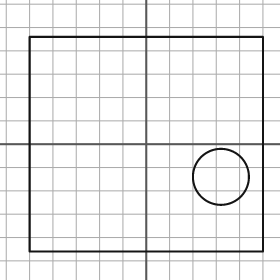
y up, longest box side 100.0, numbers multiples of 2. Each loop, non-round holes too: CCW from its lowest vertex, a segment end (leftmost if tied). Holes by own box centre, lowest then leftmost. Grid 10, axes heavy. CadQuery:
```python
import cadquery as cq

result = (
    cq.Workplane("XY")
    .moveTo(-50.0, -46.0)
    .lineTo(50.0, -46.0)
    .lineTo(50.0, 46.0)
    .lineTo(-50.0, 46.0)
    .close()
    .moveTo(32.0, -14.0)
    .circle(12.0)
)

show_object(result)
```